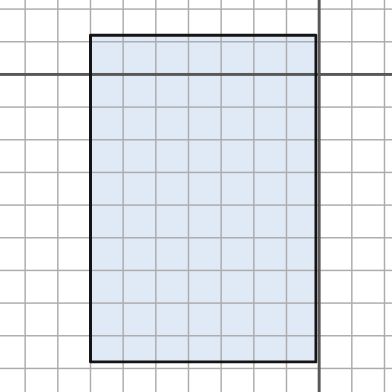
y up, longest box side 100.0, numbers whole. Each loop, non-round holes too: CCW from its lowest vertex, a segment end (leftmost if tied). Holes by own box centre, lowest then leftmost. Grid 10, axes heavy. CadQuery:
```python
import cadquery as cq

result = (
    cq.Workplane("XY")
    .moveTo(-70.0, -88.0)
    .lineTo(-1.0, -88.0)
    .lineTo(-1.0, 12.0)
    .lineTo(-70.0, 12.0)
    .close()
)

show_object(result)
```